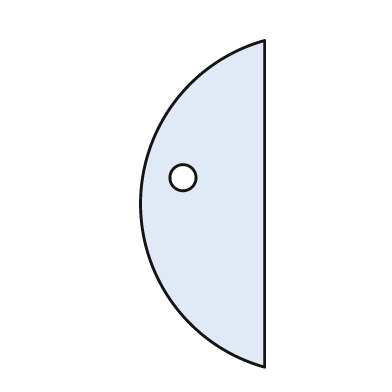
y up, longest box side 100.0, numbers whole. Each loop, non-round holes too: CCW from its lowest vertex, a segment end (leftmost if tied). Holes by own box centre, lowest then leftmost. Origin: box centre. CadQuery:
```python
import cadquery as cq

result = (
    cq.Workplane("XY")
    .moveTo(19.0, -50.0)
    .lineTo(19.0, 50.0)
    .threePointArc((-19.0, 0.0), (19.0, -50.0))
    .close()
    .moveTo(-6.0, 8.0)
    .circle(4.0)
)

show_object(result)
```